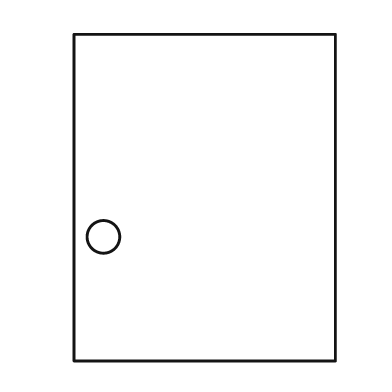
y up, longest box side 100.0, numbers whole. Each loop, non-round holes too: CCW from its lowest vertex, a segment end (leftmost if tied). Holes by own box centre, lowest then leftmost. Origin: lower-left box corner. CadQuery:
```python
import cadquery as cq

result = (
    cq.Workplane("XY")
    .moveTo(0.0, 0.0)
    .lineTo(80.0, 0.0)
    .lineTo(80.0, 100.0)
    .lineTo(0.0, 100.0)
    .close()
    .moveTo(9.0, 38.0)
    .circle(5.0)
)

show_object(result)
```